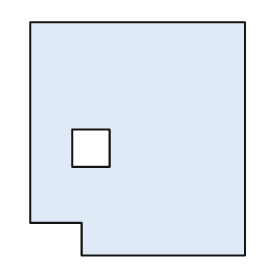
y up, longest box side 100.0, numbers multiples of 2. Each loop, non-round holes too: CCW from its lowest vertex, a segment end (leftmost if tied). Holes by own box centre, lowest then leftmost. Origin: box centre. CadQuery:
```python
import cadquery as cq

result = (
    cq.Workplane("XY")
    .moveTo(-24.0, -50.0)
    .lineTo(46.0, -50.0)
    .lineTo(46.0, 50.0)
    .lineTo(-46.0, 50.0)
    .lineTo(-46.0, -36.0)
    .lineTo(-24.0, -36.0)
    .close()
    .moveTo(-28.0, -12.0)
    .lineTo(-12.0, -12.0)
    .lineTo(-12.0, 4.0)
    .lineTo(-28.0, 4.0)
    .close()
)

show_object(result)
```